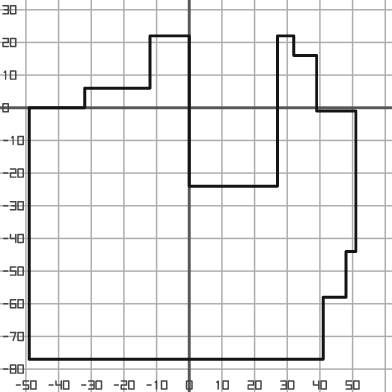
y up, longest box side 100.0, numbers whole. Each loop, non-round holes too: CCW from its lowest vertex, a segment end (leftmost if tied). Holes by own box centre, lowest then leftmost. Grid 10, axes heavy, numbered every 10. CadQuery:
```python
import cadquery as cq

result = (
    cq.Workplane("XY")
    .moveTo(-49.0, -77.0)
    .lineTo(41.0, -77.0)
    .lineTo(41.0, -58.0)
    .lineTo(48.0, -58.0)
    .lineTo(48.0, -44.0)
    .lineTo(51.0, -44.0)
    .lineTo(51.0, -1.0)
    .lineTo(39.0, -1.0)
    .lineTo(39.0, 16.0)
    .lineTo(32.0, 16.0)
    .lineTo(32.0, 22.0)
    .lineTo(27.0, 22.0)
    .lineTo(27.0, -24.0)
    .lineTo(0.0, -24.0)
    .lineTo(0.0, 22.0)
    .lineTo(-12.0, 22.0)
    .lineTo(-12.0, 6.0)
    .lineTo(-32.0, 6.0)
    .lineTo(-32.0, 0.0)
    .lineTo(-49.0, 0.0)
    .close()
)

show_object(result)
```